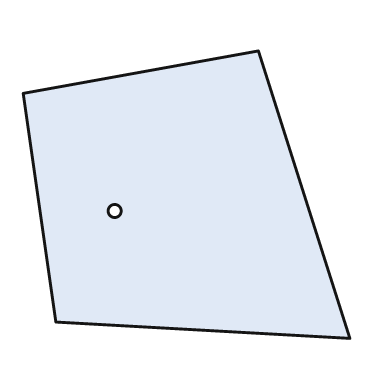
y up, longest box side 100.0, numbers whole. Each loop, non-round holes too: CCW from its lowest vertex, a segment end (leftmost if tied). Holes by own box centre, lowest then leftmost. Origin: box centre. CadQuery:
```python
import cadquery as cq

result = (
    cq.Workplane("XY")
    .moveTo(50.0, -44.0)
    .lineTo(22.0, 44.0)
    .lineTo(-50.0, 31.0)
    .lineTo(-40.0, -39.0)
    .close()
    .moveTo(-22.0, -5.0)
    .circle(2.0)
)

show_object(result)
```